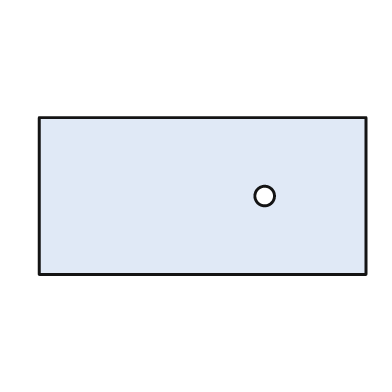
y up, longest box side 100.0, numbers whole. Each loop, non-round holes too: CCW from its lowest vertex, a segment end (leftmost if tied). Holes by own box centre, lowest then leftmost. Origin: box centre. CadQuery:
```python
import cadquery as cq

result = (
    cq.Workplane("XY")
    .moveTo(-50.0, -24.0)
    .lineTo(50.0, -24.0)
    .lineTo(50.0, 24.0)
    .lineTo(-50.0, 24.0)
    .close()
    .moveTo(19.0, 0.0)
    .circle(3.0)
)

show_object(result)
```